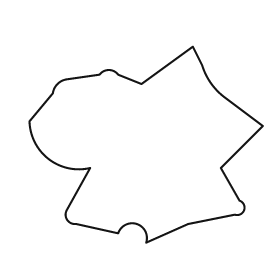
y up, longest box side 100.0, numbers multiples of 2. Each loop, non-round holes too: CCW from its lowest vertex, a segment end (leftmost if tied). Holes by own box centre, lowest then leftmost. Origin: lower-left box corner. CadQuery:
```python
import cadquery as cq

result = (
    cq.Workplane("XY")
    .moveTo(50.0, 0.0)
    .lineTo(68.0, 8.0)
    .lineTo(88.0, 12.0)
    .threePointArc((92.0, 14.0), (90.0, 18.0))
    .lineTo(82.0, 32.0)
    .lineTo(100.0, 50.0)
    .lineTo(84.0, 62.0)
    .threePointArc((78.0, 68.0), (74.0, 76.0))
    .lineTo(70.0, 84.0)
    .lineTo(48.0, 68.0)
    .lineTo(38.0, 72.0)
    .threePointArc((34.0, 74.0), (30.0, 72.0))
    .lineTo(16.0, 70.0)
    .threePointArc((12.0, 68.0), (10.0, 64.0))
    .lineTo(0.0, 52.0)
    .threePointArc((8.0, 36.0), (26.0, 32.0))
    .lineTo(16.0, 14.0)
    .threePointArc((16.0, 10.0), (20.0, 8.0))
    .lineTo(38.0, 4.0)
    .threePointArc((46.0, 8.0), (50.0, 0.0))
    .close()
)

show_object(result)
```